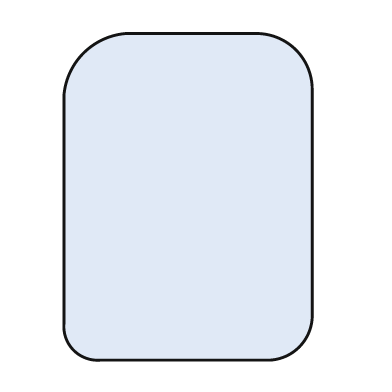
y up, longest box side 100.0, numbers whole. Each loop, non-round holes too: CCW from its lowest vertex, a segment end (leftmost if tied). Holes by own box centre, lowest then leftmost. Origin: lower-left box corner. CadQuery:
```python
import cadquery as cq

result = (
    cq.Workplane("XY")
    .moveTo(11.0, 0.0)
    .lineTo(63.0, 0.0)
    .threePointArc((72.0, 4.0), (76.0, 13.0))
    .lineTo(76.0, 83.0)
    .threePointArc((71.0, 95.0), (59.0, 100.0))
    .lineTo(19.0, 100.0)
    .threePointArc((6.0, 94.0), (0.0, 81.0))
    .lineTo(0.0, 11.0)
    .threePointArc((3.0, 3.0), (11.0, 0.0))
    .close()
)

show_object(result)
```